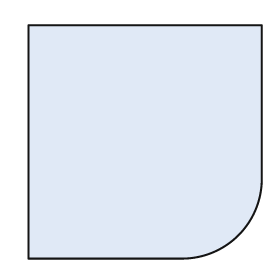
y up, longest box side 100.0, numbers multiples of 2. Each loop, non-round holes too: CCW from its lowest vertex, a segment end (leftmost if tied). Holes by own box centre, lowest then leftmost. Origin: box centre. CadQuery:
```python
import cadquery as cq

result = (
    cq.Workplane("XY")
    .moveTo(-50.0, -50.0)
    .lineTo(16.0, -50.0)
    .threePointArc((40.0, -40.0), (50.0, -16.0))
    .lineTo(50.0, 50.0)
    .lineTo(-50.0, 50.0)
    .close()
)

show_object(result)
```